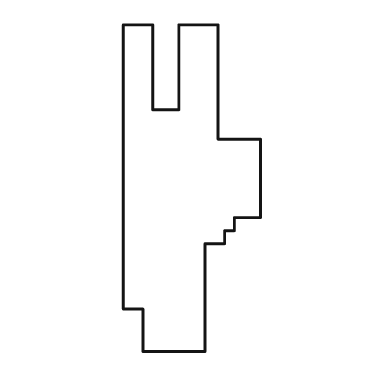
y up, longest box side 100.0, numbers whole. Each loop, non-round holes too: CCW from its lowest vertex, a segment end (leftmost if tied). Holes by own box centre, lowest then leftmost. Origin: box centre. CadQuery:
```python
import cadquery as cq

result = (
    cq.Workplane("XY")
    .moveTo(-15.0, -50.0)
    .lineTo(4.0, -50.0)
    .lineTo(4.0, -17.0)
    .lineTo(10.0, -17.0)
    .lineTo(10.0, -13.0)
    .lineTo(13.0, -13.0)
    .lineTo(13.0, -9.0)
    .lineTo(21.0, -9.0)
    .lineTo(21.0, 15.0)
    .lineTo(8.0, 15.0)
    .lineTo(8.0, 50.0)
    .lineTo(-4.0, 50.0)
    .lineTo(-4.0, 24.0)
    .lineTo(-12.0, 24.0)
    .lineTo(-12.0, 50.0)
    .lineTo(-21.0, 50.0)
    .lineTo(-21.0, -37.0)
    .lineTo(-15.0, -37.0)
    .close()
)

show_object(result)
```